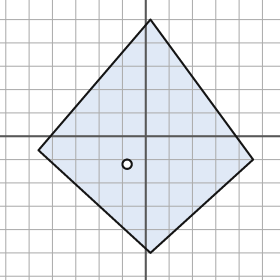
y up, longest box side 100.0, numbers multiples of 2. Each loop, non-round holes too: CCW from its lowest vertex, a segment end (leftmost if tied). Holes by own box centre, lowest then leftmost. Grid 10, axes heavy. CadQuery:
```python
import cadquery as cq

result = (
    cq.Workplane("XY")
    .moveTo(2.0, -50.0)
    .lineTo(46.0, -10.0)
    .lineTo(2.0, 50.0)
    .lineTo(-46.0, -6.0)
    .close()
    .moveTo(-8.0, -12.0)
    .circle(2.0)
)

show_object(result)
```